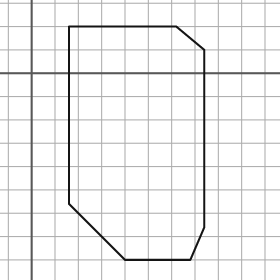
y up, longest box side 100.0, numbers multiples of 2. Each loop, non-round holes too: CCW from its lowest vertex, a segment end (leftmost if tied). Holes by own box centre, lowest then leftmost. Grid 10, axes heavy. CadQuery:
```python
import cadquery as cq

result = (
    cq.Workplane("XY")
    .moveTo(40.0, -80.0)
    .lineTo(68.0, -80.0)
    .lineTo(74.0, -66.0)
    .lineTo(74.0, 10.0)
    .lineTo(62.0, 20.0)
    .lineTo(16.0, 20.0)
    .lineTo(16.0, -56.0)
    .close()
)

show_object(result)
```